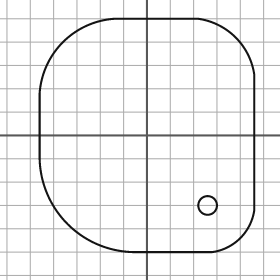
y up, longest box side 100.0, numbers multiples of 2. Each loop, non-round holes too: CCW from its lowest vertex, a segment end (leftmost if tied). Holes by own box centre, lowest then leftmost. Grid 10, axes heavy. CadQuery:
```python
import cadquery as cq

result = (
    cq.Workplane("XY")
    .moveTo(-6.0, -50.0)
    .lineTo(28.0, -50.0)
    .threePointArc((40.0, -44.0), (46.0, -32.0))
    .lineTo(46.0, 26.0)
    .threePointArc((38.0, 42.0), (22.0, 50.0))
    .lineTo(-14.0, 50.0)
    .threePointArc((-36.0, 40.0), (-46.0, 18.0))
    .lineTo(-46.0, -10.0)
    .threePointArc((-34.0, -38.0), (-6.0, -50.0))
    .close()
    .moveTo(26.0, -30.0)
    .circle(4.0)
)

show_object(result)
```